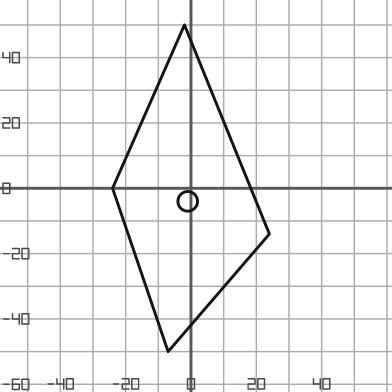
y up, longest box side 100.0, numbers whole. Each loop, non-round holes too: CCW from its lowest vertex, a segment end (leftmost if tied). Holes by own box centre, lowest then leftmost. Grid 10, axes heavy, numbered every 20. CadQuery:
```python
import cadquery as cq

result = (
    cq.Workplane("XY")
    .moveTo(-7.0, -50.0)
    .lineTo(24.0, -14.0)
    .lineTo(-2.0, 50.0)
    .lineTo(-24.0, 0.0)
    .close()
    .moveTo(-1.0, -4.0)
    .circle(3.0)
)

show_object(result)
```